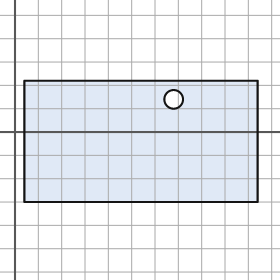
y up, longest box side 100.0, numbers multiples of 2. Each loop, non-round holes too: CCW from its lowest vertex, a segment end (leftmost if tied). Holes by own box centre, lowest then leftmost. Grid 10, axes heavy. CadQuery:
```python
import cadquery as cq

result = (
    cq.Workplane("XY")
    .moveTo(4.0, -30.0)
    .lineTo(104.0, -30.0)
    .lineTo(104.0, 22.0)
    .lineTo(4.0, 22.0)
    .close()
    .moveTo(68.0, 14.0)
    .circle(4.0)
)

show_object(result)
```